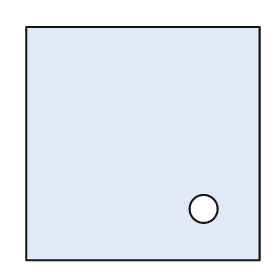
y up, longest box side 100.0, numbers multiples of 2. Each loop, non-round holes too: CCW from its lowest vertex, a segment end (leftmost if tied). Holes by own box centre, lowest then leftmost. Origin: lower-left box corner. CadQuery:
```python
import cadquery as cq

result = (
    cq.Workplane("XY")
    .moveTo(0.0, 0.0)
    .lineTo(100.0, 0.0)
    .lineTo(100.0, 100.0)
    .lineTo(0.0, 100.0)
    .close()
    .moveTo(76.0, 22.0)
    .circle(6.0)
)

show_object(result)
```